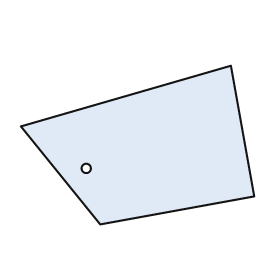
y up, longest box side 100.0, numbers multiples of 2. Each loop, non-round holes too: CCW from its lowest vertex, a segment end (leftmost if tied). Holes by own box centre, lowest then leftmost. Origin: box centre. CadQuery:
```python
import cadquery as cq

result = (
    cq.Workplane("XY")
    .moveTo(-16.0, -34.0)
    .lineTo(50.0, -22.0)
    .lineTo(40.0, 34.0)
    .lineTo(-50.0, 8.0)
    .close()
    .moveTo(-22.0, -10.0)
    .circle(2.0)
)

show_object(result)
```